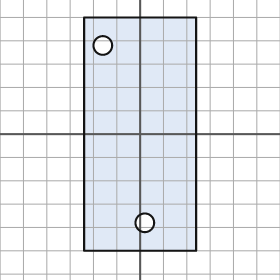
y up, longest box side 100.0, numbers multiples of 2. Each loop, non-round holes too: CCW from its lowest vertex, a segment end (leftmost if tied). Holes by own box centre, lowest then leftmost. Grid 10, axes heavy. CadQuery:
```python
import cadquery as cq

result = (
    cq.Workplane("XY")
    .moveTo(-24.0, -50.0)
    .lineTo(24.0, -50.0)
    .lineTo(24.0, 50.0)
    .lineTo(-24.0, 50.0)
    .close()
    .moveTo(2.0, -38.0)
    .circle(4.0)
    .moveTo(-16.0, 38.0)
    .circle(4.0)
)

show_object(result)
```